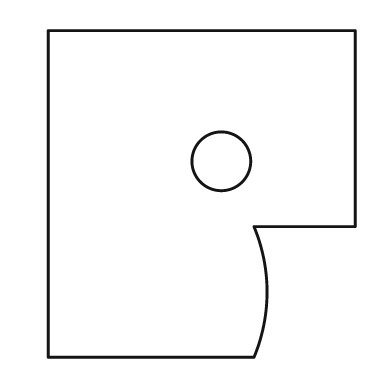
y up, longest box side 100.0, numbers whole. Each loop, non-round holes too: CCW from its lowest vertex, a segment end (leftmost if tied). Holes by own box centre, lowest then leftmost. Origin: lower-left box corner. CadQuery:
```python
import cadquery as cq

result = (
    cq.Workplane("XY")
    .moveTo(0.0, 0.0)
    .lineTo(63.0, 0.0)
    .threePointArc((67.0, 20.0), (63.0, 40.0))
    .lineTo(94.0, 40.0)
    .lineTo(94.0, 100.0)
    .lineTo(0.0, 100.0)
    .close()
    .moveTo(53.0, 60.0)
    .circle(9.0)
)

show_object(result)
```